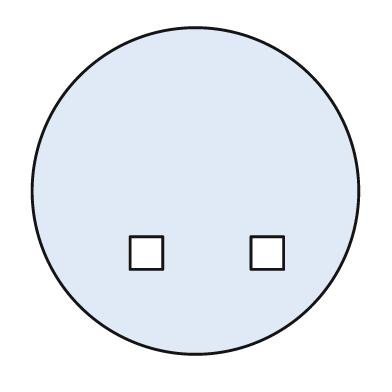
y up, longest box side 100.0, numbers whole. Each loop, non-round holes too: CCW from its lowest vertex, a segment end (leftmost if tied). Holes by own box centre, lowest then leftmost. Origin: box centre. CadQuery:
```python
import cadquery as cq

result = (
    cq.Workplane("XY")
    .moveTo(0.0, 0.0)
    .circle(50.0)
    .moveTo(-20.0, -24.0)
    .lineTo(-10.0, -24.0)
    .lineTo(-10.0, -14.0)
    .lineTo(-20.0, -14.0)
    .close()
    .moveTo(17.0, -24.0)
    .lineTo(27.0, -24.0)
    .lineTo(27.0, -14.0)
    .lineTo(17.0, -14.0)
    .close()
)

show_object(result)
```